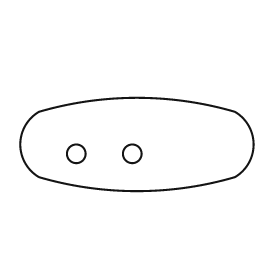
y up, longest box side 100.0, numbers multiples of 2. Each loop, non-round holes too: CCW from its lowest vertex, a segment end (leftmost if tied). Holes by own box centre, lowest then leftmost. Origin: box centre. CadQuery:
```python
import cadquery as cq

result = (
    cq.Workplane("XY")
    .moveTo(-42.0, -14.0)
    .threePointArc((0.0, -20.0), (42.0, -14.0))
    .threePointArc((50.0, 0.0), (42.0, 14.0))
    .threePointArc((0.0, 20.0), (-42.0, 14.0))
    .threePointArc((-50.0, 0.0), (-42.0, -14.0))
    .close()
    .moveTo(-26.0, -4.0)
    .circle(4.0)
    .moveTo(-2.0, -4.0)
    .circle(4.0)
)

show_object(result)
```